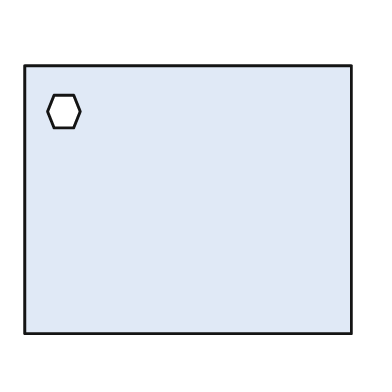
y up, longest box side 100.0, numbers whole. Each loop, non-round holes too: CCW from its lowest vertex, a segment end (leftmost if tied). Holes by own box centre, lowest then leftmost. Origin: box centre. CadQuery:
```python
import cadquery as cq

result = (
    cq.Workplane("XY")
    .moveTo(-50.0, -41.0)
    .lineTo(50.0, -41.0)
    .lineTo(50.0, 41.0)
    .lineTo(-50.0, 41.0)
    .close()
    .moveTo(-41.0, 22.0)
    .lineTo(-35.0, 22.0)
    .lineTo(-33.0, 27.0)
    .lineTo(-35.0, 32.0)
    .lineTo(-41.0, 32.0)
    .lineTo(-43.0, 27.0)
    .close()
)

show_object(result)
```